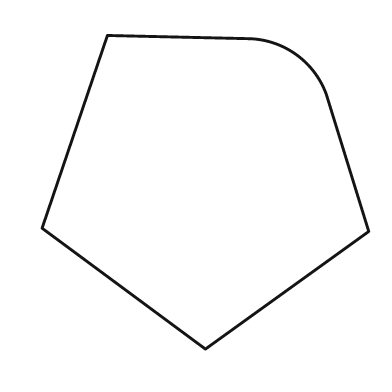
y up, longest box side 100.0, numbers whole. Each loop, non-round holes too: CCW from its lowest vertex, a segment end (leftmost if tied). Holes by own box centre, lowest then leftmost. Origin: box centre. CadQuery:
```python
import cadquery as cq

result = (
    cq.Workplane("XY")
    .moveTo(0.0, -48.0)
    .lineTo(50.0, -12.0)
    .lineTo(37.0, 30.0)
    .threePointArc((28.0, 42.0), (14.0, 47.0))
    .lineTo(-30.0, 48.0)
    .lineTo(-50.0, -11.0)
    .close()
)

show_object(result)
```